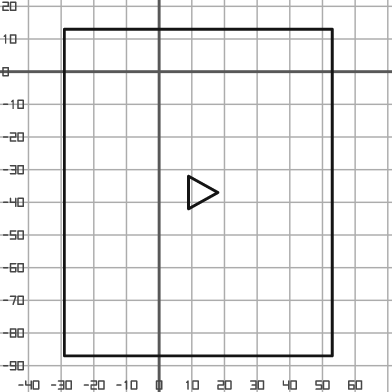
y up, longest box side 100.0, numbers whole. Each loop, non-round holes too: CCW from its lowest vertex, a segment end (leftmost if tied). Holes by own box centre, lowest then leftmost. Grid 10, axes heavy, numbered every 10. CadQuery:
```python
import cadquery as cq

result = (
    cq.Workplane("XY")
    .moveTo(-29.0, -87.0)
    .lineTo(53.0, -87.0)
    .lineTo(53.0, 13.0)
    .lineTo(-29.0, 13.0)
    .close()
    .moveTo(9.0, -42.0)
    .lineTo(18.0, -37.0)
    .lineTo(9.0, -32.0)
    .close()
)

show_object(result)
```